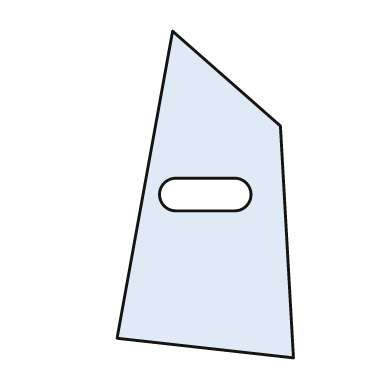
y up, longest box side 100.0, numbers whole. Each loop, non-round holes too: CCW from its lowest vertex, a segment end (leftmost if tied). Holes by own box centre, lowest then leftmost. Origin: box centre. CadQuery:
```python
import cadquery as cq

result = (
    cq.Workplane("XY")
    .moveTo(27.0, -50.0)
    .lineTo(23.0, 21.0)
    .lineTo(-10.0, 50.0)
    .lineTo(-27.0, -44.0)
    .close()
    .moveTo(-9.0, -5.0)
    .lineTo(9.0, -5.0)
    .threePointArc((14.0, 0.0), (9.0, 5.0))
    .lineTo(-9.0, 5.0)
    .threePointArc((-14.0, 0.0), (-9.0, -5.0))
    .close()
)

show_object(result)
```